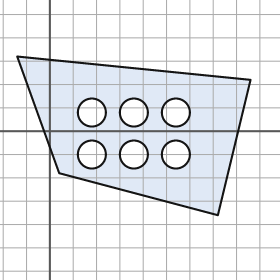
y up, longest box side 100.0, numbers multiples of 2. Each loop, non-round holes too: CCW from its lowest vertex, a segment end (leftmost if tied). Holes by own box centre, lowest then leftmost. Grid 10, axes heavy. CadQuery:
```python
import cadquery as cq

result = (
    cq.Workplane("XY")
    .moveTo(72.0, -36.0)
    .lineTo(86.0, 22.0)
    .lineTo(-14.0, 32.0)
    .lineTo(4.0, -18.0)
    .close()
    .moveTo(18.0, -10.0)
    .circle(6.0)
    .moveTo(36.0, -10.0)
    .circle(6.0)
    .moveTo(54.0, -10.0)
    .circle(6.0)
    .moveTo(18.0, 8.0)
    .circle(6.0)
    .moveTo(36.0, 8.0)
    .circle(6.0)
    .moveTo(54.0, 8.0)
    .circle(6.0)
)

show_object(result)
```